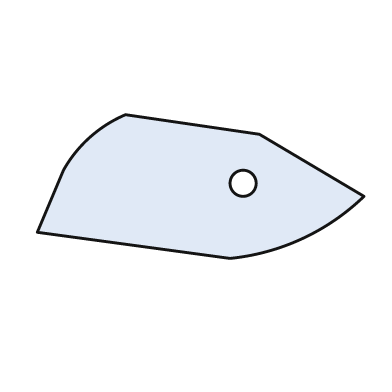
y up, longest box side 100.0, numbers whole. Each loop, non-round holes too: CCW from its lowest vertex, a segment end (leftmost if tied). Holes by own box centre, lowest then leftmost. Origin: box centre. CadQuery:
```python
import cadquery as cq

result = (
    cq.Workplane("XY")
    .moveTo(9.0, -22.0)
    .threePointArc((31.0, -16.0), (50.0, -3.0))
    .lineTo(18.0, 16.0)
    .lineTo(-23.0, 22.0)
    .threePointArc((-34.0, 15.0), (-42.0, 5.0))
    .lineTo(-50.0, -14.0)
    .close()
    .moveTo(13.0, 1.0)
    .circle(4.0)
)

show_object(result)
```